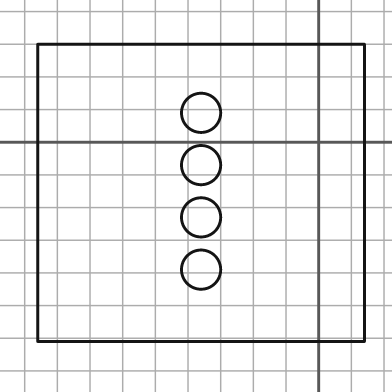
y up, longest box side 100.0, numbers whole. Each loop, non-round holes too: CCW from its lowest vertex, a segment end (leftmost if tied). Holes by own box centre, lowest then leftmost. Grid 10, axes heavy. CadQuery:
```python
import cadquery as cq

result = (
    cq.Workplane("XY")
    .moveTo(-86.0, -61.0)
    .lineTo(14.0, -61.0)
    .lineTo(14.0, 30.0)
    .lineTo(-86.0, 30.0)
    .close()
    .moveTo(-36.0, -39.0)
    .circle(6.0)
    .moveTo(-36.0, -23.0)
    .circle(6.0)
    .moveTo(-36.0, -7.0)
    .circle(6.0)
    .moveTo(-36.0, 9.0)
    .circle(6.0)
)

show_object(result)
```